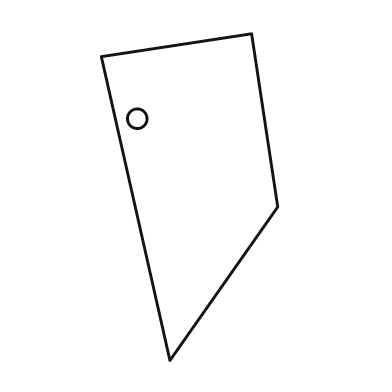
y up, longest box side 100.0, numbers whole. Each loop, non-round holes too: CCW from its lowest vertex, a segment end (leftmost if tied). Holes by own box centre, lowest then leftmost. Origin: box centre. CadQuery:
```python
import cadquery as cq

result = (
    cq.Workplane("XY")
    .moveTo(-6.0, -50.0)
    .lineTo(27.0, -3.0)
    .lineTo(19.0, 50.0)
    .lineTo(-27.0, 43.0)
    .close()
    .moveTo(-16.0, 24.0)
    .circle(3.0)
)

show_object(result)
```